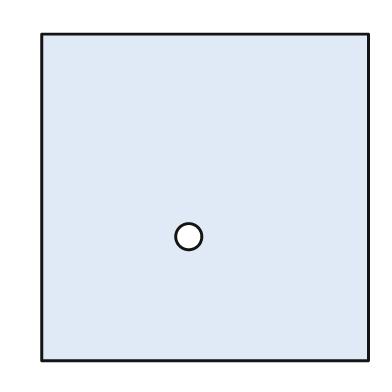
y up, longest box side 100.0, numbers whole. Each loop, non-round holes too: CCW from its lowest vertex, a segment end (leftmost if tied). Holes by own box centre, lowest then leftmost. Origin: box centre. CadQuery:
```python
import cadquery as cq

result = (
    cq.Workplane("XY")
    .moveTo(-50.0, -50.0)
    .lineTo(50.0, -50.0)
    .lineTo(50.0, 50.0)
    .lineTo(-50.0, 50.0)
    .close()
    .moveTo(-5.0, -12.0)
    .circle(4.0)
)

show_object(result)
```